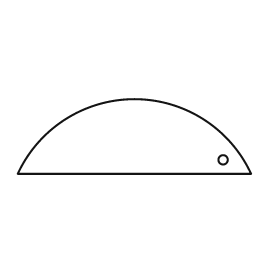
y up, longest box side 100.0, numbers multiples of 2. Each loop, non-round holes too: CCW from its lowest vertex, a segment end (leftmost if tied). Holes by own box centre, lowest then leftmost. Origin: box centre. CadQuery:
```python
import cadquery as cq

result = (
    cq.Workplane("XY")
    .moveTo(-50.0, -16.0)
    .lineTo(50.0, -16.0)
    .threePointArc((0.0, 16.0), (-50.0, -16.0))
    .close()
    .moveTo(38.0, -10.0)
    .circle(2.0)
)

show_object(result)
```